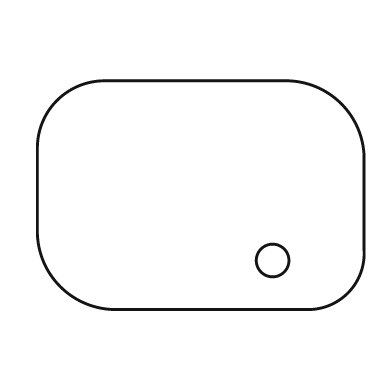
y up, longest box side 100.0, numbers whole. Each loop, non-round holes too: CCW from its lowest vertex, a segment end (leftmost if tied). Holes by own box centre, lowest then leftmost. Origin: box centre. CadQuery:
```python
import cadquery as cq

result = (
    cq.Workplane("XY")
    .moveTo(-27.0, -35.0)
    .lineTo(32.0, -35.0)
    .threePointArc((45.0, -30.0), (50.0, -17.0))
    .lineTo(50.0, 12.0)
    .threePointArc((43.0, 28.0), (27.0, 35.0))
    .lineTo(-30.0, 35.0)
    .threePointArc((-44.0, 29.0), (-50.0, 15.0))
    .lineTo(-50.0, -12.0)
    .threePointArc((-43.0, -28.0), (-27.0, -35.0))
    .close()
    .moveTo(22.0, -20.0)
    .circle(5.0)
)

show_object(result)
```